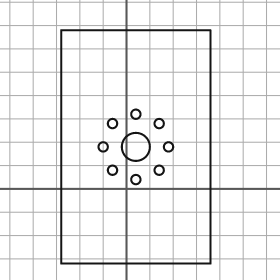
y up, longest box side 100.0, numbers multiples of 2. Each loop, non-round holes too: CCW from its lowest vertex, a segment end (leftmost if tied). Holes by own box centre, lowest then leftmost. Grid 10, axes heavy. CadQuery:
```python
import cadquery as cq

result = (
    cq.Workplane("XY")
    .moveTo(-28.0, -32.0)
    .lineTo(36.0, -32.0)
    .lineTo(36.0, 68.0)
    .lineTo(-28.0, 68.0)
    .close()
    .moveTo(4.0, 4.0)
    .circle(2.0)
    .moveTo(-6.0, 8.0)
    .circle(2.0)
    .moveTo(14.0, 8.0)
    .circle(2.0)
    .moveTo(-10.0, 18.0)
    .circle(2.0)
    .moveTo(4.0, 18.0)
    .circle(6.0)
    .moveTo(18.0, 18.0)
    .circle(2.0)
    .moveTo(-6.0, 28.0)
    .circle(2.0)
    .moveTo(14.0, 28.0)
    .circle(2.0)
    .moveTo(4.0, 32.0)
    .circle(2.0)
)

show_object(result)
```